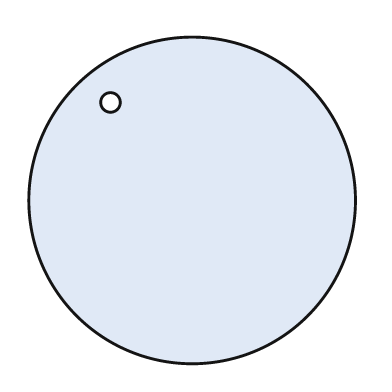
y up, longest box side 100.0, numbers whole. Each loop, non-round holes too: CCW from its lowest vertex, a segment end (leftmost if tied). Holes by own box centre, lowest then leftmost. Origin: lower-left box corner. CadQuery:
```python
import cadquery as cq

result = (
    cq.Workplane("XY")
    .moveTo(50.0, 50.0)
    .circle(50.0)
    .moveTo(25.0, 80.0)
    .circle(3.0)
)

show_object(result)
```